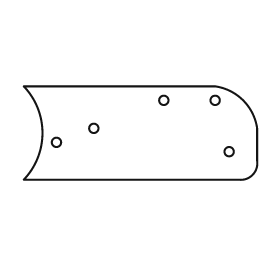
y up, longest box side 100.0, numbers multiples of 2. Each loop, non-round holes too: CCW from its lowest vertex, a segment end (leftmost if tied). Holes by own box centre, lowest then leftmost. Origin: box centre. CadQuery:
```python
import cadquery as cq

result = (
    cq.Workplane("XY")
    .moveTo(-50.0, -20.0)
    .lineTo(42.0, -20.0)
    .threePointArc((48.0, -18.0), (50.0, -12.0))
    .lineTo(50.0, 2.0)
    .threePointArc((44.0, 14.0), (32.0, 20.0))
    .lineTo(-50.0, 20.0)
    .threePointArc((-42.0, 0.0), (-50.0, -20.0))
    .close()
    .moveTo(38.0, -8.0)
    .circle(2.0)
    .moveTo(-36.0, -4.0)
    .circle(2.0)
    .moveTo(-20.0, 2.0)
    .circle(2.0)
    .moveTo(10.0, 14.0)
    .circle(2.0)
    .moveTo(32.0, 14.0)
    .circle(2.0)
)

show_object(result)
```